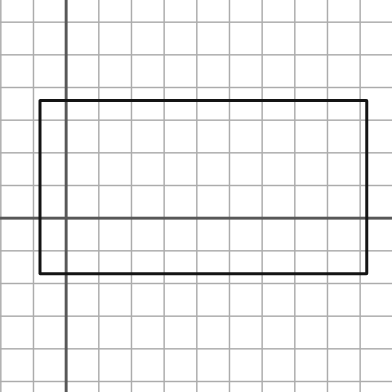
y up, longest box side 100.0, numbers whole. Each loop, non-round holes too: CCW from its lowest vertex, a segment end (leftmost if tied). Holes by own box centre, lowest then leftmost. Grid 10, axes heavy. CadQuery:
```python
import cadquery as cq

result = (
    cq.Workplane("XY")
    .moveTo(-8.0, -17.0)
    .lineTo(92.0, -17.0)
    .lineTo(92.0, 36.0)
    .lineTo(-8.0, 36.0)
    .close()
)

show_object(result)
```